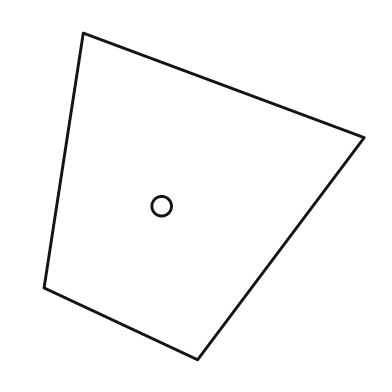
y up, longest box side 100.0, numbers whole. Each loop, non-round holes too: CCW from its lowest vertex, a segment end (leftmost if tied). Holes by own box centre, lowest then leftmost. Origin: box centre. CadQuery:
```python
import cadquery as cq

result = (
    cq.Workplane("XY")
    .moveTo(-2.0, -50.0)
    .lineTo(49.0, 18.0)
    .lineTo(-37.0, 50.0)
    .lineTo(-49.0, -28.0)
    .close()
    .moveTo(-13.0, -3.0)
    .circle(3.0)
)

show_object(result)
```